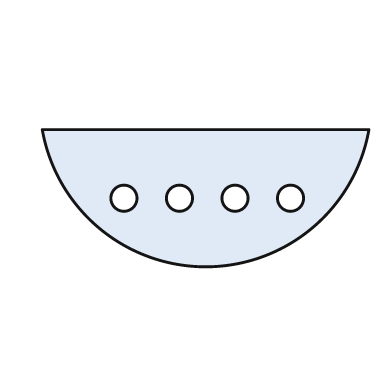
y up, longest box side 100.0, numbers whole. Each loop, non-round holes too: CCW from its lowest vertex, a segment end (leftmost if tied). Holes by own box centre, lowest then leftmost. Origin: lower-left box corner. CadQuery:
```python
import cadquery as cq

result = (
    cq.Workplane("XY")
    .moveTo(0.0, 42.0)
    .threePointArc((50.0, 0.0), (100.0, 42.0))
    .close()
    .moveTo(25.0, 21.0)
    .circle(4.0)
    .moveTo(42.0, 21.0)
    .circle(4.0)
    .moveTo(59.0, 21.0)
    .circle(4.0)
    .moveTo(76.0, 21.0)
    .circle(4.0)
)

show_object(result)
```